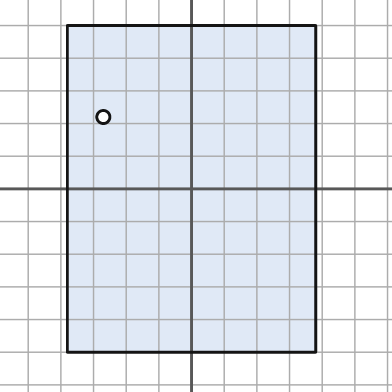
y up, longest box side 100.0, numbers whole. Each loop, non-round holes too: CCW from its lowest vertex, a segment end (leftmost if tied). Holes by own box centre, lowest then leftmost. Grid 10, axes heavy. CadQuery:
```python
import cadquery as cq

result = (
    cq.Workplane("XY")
    .moveTo(-38.0, -50.0)
    .lineTo(38.0, -50.0)
    .lineTo(38.0, 50.0)
    .lineTo(-38.0, 50.0)
    .close()
    .moveTo(-27.0, 22.0)
    .circle(2.0)
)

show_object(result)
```